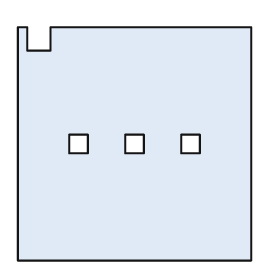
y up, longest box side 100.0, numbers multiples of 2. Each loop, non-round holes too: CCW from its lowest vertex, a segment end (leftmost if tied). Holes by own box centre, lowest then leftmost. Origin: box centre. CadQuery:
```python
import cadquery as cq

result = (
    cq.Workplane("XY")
    .moveTo(-50.0, -50.0)
    .lineTo(50.0, -50.0)
    .lineTo(50.0, 50.0)
    .lineTo(-36.0, 50.0)
    .lineTo(-36.0, 40.0)
    .lineTo(-46.0, 40.0)
    .lineTo(-46.0, 50.0)
    .lineTo(-50.0, 50.0)
    .close()
    .moveTo(-28.0, -4.0)
    .lineTo(-20.0, -4.0)
    .lineTo(-20.0, 4.0)
    .lineTo(-28.0, 4.0)
    .close()
    .moveTo(-4.0, -4.0)
    .lineTo(4.0, -4.0)
    .lineTo(4.0, 4.0)
    .lineTo(-4.0, 4.0)
    .close()
    .moveTo(20.0, -4.0)
    .lineTo(28.0, -4.0)
    .lineTo(28.0, 4.0)
    .lineTo(20.0, 4.0)
    .close()
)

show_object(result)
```